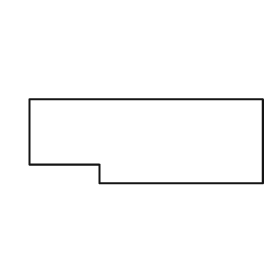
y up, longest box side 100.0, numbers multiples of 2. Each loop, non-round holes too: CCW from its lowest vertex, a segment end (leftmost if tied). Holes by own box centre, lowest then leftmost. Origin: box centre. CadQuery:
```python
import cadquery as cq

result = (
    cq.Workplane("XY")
    .moveTo(-20.0, -18.0)
    .lineTo(50.0, -18.0)
    .lineTo(50.0, 18.0)
    .lineTo(-50.0, 18.0)
    .lineTo(-50.0, -10.0)
    .lineTo(-20.0, -10.0)
    .close()
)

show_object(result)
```